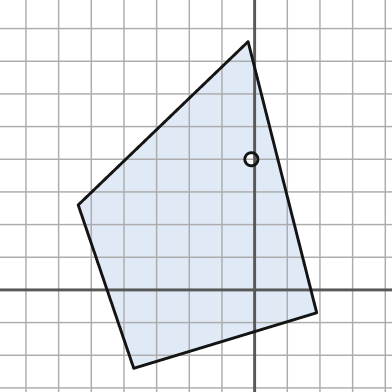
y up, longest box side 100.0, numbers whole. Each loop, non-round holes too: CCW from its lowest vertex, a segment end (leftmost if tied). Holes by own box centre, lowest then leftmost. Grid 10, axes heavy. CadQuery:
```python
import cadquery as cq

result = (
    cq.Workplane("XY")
    .moveTo(-37.0, -24.0)
    .lineTo(19.0, -7.0)
    .lineTo(-2.0, 76.0)
    .lineTo(-54.0, 26.0)
    .close()
    .moveTo(-1.0, 40.0)
    .circle(2.0)
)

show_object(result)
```